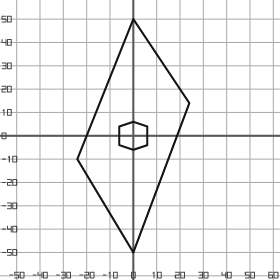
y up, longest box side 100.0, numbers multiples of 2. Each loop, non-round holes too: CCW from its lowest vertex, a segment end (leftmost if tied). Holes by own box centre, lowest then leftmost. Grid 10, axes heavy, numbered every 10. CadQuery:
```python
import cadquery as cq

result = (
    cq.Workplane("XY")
    .moveTo(0.0, -50.0)
    .lineTo(24.0, 14.0)
    .lineTo(0.0, 50.0)
    .lineTo(-24.0, -10.0)
    .close()
    .moveTo(0.0, -6.0)
    .lineTo(6.0, -4.0)
    .lineTo(6.0, 4.0)
    .lineTo(0.0, 6.0)
    .lineTo(-6.0, 4.0)
    .lineTo(-6.0, -4.0)
    .close()
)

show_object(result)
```